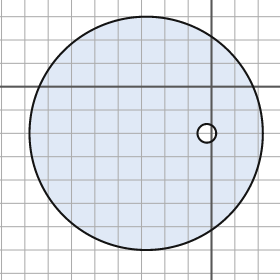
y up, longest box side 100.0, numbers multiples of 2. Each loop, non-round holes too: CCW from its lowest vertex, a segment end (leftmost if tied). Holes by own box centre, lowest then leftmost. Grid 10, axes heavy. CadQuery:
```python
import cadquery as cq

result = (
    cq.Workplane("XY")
    .moveTo(-28.0, -20.0)
    .circle(50.0)
    .moveTo(-2.0, -20.0)
    .circle(4.0)
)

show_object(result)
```